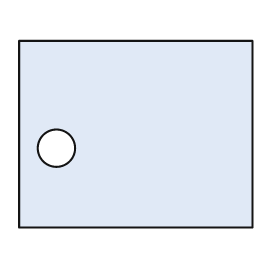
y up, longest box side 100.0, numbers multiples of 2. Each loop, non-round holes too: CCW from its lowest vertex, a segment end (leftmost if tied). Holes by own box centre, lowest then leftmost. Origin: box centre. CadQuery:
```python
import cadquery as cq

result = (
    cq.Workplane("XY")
    .moveTo(-50.0, -40.0)
    .lineTo(50.0, -40.0)
    .lineTo(50.0, 40.0)
    .lineTo(-50.0, 40.0)
    .close()
    .moveTo(-34.0, -6.0)
    .circle(8.0)
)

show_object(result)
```